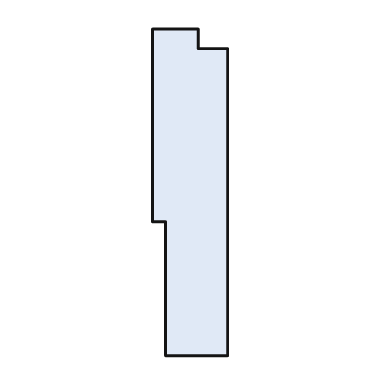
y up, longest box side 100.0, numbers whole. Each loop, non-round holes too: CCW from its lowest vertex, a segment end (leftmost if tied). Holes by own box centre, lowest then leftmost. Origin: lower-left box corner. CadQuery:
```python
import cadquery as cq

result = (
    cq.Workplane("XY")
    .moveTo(4.0, 0.0)
    .lineTo(23.0, 0.0)
    .lineTo(23.0, 94.0)
    .lineTo(14.0, 94.0)
    .lineTo(14.0, 100.0)
    .lineTo(0.0, 100.0)
    .lineTo(0.0, 41.0)
    .lineTo(4.0, 41.0)
    .close()
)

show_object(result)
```